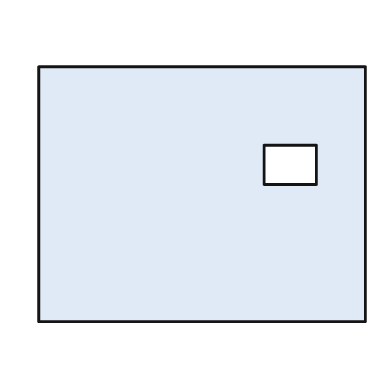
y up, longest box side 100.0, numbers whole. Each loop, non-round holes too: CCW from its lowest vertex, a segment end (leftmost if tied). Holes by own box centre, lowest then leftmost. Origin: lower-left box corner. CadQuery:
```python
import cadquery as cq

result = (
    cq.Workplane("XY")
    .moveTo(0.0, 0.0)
    .lineTo(100.0, 0.0)
    .lineTo(100.0, 78.0)
    .lineTo(0.0, 78.0)
    .close()
    .moveTo(69.0, 42.0)
    .lineTo(85.0, 42.0)
    .lineTo(85.0, 54.0)
    .lineTo(69.0, 54.0)
    .close()
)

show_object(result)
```